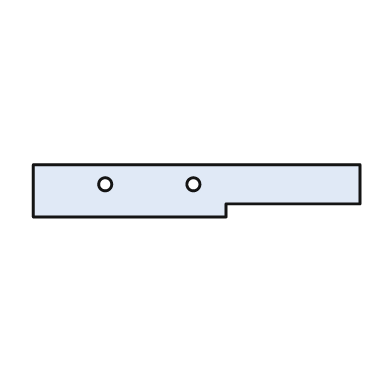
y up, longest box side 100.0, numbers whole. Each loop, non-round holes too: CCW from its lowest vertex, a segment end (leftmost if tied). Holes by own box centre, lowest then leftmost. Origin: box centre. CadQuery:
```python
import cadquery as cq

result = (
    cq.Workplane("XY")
    .moveTo(-50.0, -8.0)
    .lineTo(9.0, -8.0)
    .lineTo(9.0, -4.0)
    .lineTo(50.0, -4.0)
    .lineTo(50.0, 8.0)
    .lineTo(-50.0, 8.0)
    .close()
    .moveTo(-28.0, 2.0)
    .circle(2.0)
    .moveTo(-1.0, 2.0)
    .circle(2.0)
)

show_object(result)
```